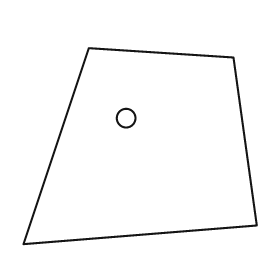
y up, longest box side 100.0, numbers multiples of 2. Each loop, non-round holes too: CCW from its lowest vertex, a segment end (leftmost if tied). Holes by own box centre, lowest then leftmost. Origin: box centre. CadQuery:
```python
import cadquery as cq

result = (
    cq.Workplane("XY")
    .moveTo(-50.0, -42.0)
    .lineTo(50.0, -34.0)
    .lineTo(40.0, 38.0)
    .lineTo(-22.0, 42.0)
    .close()
    .moveTo(-6.0, 12.0)
    .circle(4.0)
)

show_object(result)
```